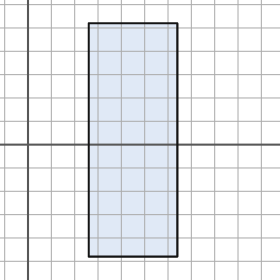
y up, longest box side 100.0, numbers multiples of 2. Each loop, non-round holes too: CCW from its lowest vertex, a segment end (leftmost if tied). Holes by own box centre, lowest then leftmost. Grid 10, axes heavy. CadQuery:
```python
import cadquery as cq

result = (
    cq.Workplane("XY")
    .moveTo(26.0, -48.0)
    .lineTo(64.0, -48.0)
    .lineTo(64.0, 52.0)
    .lineTo(26.0, 52.0)
    .close()
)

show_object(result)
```